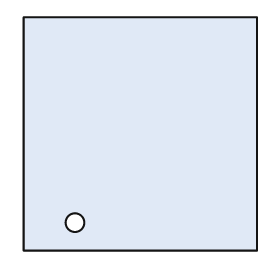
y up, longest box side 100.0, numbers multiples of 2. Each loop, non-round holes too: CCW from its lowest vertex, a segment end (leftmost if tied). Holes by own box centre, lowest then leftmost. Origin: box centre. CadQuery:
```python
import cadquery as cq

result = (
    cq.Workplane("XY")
    .moveTo(-50.0, -50.0)
    .lineTo(50.0, -50.0)
    .lineTo(50.0, 50.0)
    .lineTo(-50.0, 50.0)
    .close()
    .moveTo(-28.0, -38.0)
    .circle(4.0)
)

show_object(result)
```